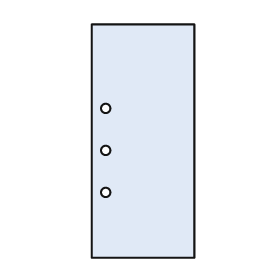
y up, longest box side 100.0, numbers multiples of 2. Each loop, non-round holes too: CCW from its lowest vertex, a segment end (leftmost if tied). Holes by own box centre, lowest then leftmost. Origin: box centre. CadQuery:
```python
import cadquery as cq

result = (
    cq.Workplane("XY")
    .moveTo(-22.0, -50.0)
    .lineTo(22.0, -50.0)
    .lineTo(22.0, 50.0)
    .lineTo(-22.0, 50.0)
    .close()
    .moveTo(-16.0, -22.0)
    .circle(2.0)
    .moveTo(-16.0, -4.0)
    .circle(2.0)
    .moveTo(-16.0, 14.0)
    .circle(2.0)
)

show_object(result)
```